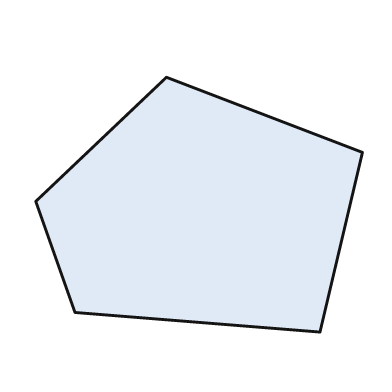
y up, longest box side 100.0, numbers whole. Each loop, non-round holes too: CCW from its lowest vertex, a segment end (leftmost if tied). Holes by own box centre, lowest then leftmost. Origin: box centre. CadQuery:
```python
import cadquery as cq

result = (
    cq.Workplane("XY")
    .moveTo(37.0, -39.0)
    .lineTo(50.0, 16.0)
    .lineTo(-10.0, 39.0)
    .lineTo(-50.0, 1.0)
    .lineTo(-38.0, -33.0)
    .close()
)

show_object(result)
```